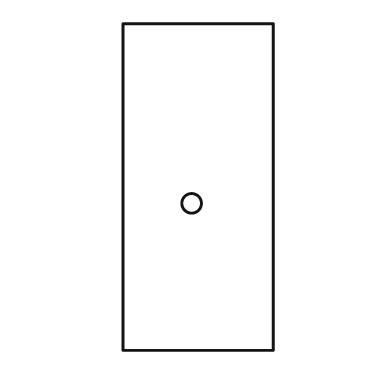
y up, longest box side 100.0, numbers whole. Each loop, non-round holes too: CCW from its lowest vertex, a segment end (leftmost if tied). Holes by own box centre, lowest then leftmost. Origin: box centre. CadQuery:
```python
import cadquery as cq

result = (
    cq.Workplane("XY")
    .moveTo(-23.0, -50.0)
    .lineTo(23.0, -50.0)
    .lineTo(23.0, 50.0)
    .lineTo(-23.0, 50.0)
    .close()
    .moveTo(-2.0, -5.0)
    .circle(3.0)
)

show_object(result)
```